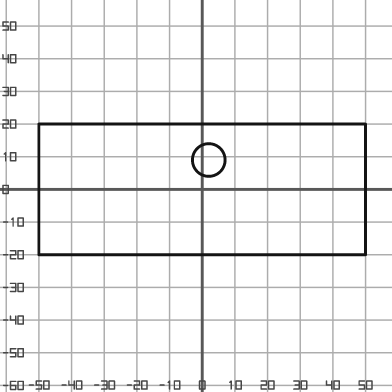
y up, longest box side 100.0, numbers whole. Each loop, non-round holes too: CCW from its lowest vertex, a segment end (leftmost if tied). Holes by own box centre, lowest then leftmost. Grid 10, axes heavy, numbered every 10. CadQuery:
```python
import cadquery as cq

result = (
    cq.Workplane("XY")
    .moveTo(-50.0, -20.0)
    .lineTo(50.0, -20.0)
    .lineTo(50.0, 20.0)
    .lineTo(-50.0, 20.0)
    .close()
    .moveTo(2.0, 9.0)
    .circle(5.0)
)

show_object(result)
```